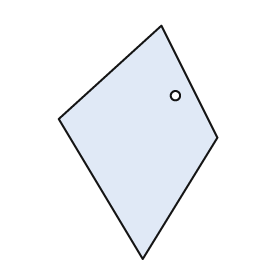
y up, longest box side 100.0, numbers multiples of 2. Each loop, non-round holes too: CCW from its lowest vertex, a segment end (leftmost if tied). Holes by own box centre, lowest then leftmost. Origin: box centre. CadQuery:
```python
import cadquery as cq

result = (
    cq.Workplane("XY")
    .moveTo(2.0, -50.0)
    .lineTo(34.0, 2.0)
    .lineTo(10.0, 50.0)
    .lineTo(-34.0, 10.0)
    .close()
    .moveTo(16.0, 20.0)
    .circle(2.0)
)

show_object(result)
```